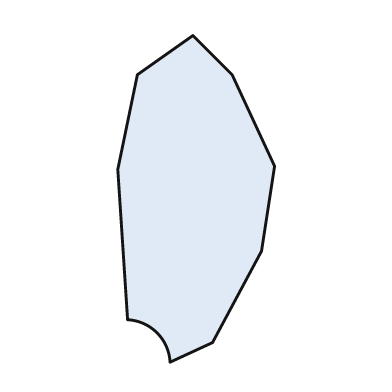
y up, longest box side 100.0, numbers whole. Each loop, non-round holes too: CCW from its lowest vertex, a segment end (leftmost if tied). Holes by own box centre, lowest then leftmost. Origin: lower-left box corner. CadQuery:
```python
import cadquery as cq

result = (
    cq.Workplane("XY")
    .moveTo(16.0, 0.0)
    .lineTo(29.0, 6.0)
    .lineTo(44.0, 34.0)
    .lineTo(48.0, 60.0)
    .lineTo(35.0, 88.0)
    .lineTo(23.0, 100.0)
    .lineTo(6.0, 88.0)
    .lineTo(0.0, 59.0)
    .lineTo(3.0, 13.0)
    .threePointArc((12.0, 9.0), (16.0, 0.0))
    .close()
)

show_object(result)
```